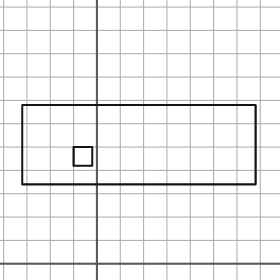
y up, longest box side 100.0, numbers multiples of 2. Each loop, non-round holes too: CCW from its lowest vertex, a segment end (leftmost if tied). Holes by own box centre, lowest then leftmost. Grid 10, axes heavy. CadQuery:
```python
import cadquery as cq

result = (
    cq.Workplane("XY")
    .moveTo(-32.0, 34.0)
    .lineTo(68.0, 34.0)
    .lineTo(68.0, 68.0)
    .lineTo(-32.0, 68.0)
    .close()
    .moveTo(-10.0, 42.0)
    .lineTo(-2.0, 42.0)
    .lineTo(-2.0, 50.0)
    .lineTo(-10.0, 50.0)
    .close()
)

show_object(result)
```